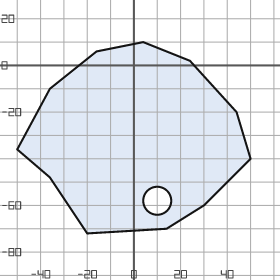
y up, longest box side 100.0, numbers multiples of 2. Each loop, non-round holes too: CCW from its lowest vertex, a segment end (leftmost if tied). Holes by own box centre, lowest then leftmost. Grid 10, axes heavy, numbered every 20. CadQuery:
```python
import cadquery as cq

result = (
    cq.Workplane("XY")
    .moveTo(-20.0, -72.0)
    .lineTo(14.0, -70.0)
    .lineTo(30.0, -60.0)
    .lineTo(50.0, -40.0)
    .lineTo(44.0, -20.0)
    .lineTo(24.0, 2.0)
    .lineTo(4.0, 10.0)
    .lineTo(-16.0, 6.0)
    .lineTo(-36.0, -10.0)
    .lineTo(-50.0, -36.0)
    .lineTo(-36.0, -48.0)
    .close()
    .moveTo(10.0, -58.0)
    .circle(6.0)
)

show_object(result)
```